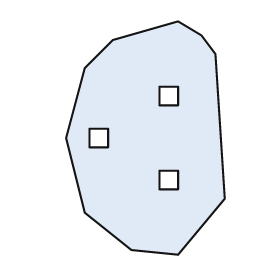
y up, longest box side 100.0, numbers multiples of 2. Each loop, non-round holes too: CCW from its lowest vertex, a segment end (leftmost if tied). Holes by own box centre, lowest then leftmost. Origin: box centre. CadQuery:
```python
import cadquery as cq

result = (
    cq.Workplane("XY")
    .moveTo(14.0, -50.0)
    .lineTo(34.0, -26.0)
    .lineTo(30.0, 36.0)
    .lineTo(24.0, 44.0)
    .lineTo(14.0, 50.0)
    .lineTo(-14.0, 42.0)
    .lineTo(-26.0, 30.0)
    .lineTo(-34.0, 0.0)
    .lineTo(-26.0, -32.0)
    .lineTo(-6.0, -48.0)
    .close()
    .moveTo(6.0, -22.0)
    .lineTo(14.0, -22.0)
    .lineTo(14.0, -14.0)
    .lineTo(6.0, -14.0)
    .close()
    .moveTo(-24.0, -4.0)
    .lineTo(-16.0, -4.0)
    .lineTo(-16.0, 4.0)
    .lineTo(-24.0, 4.0)
    .close()
    .moveTo(6.0, 14.0)
    .lineTo(14.0, 14.0)
    .lineTo(14.0, 22.0)
    .lineTo(6.0, 22.0)
    .close()
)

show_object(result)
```